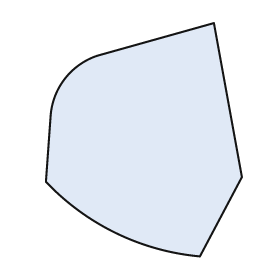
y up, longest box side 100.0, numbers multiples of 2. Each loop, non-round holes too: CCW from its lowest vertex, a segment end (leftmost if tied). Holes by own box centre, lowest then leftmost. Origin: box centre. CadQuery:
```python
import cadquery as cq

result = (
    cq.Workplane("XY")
    .moveTo(24.0, -50.0)
    .lineTo(42.0, -16.0)
    .lineTo(30.0, 50.0)
    .lineTo(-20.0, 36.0)
    .threePointArc((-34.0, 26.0), (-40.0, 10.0))
    .lineTo(-42.0, -18.0)
    .threePointArc((-12.0, -40.0), (24.0, -50.0))
    .close()
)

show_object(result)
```